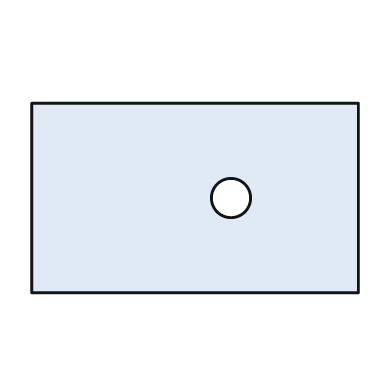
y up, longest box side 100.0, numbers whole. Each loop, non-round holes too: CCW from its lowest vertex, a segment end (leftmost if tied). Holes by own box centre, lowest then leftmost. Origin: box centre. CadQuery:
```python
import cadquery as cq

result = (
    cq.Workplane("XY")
    .moveTo(-50.0, -29.0)
    .lineTo(50.0, -29.0)
    .lineTo(50.0, 29.0)
    .lineTo(-50.0, 29.0)
    .close()
    .moveTo(11.0, 0.0)
    .circle(6.0)
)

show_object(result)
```